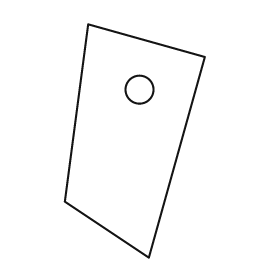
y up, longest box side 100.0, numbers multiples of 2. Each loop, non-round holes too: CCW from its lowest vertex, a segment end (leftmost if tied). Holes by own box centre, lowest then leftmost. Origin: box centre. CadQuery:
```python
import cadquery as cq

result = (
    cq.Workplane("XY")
    .moveTo(6.0, -50.0)
    .lineTo(30.0, 36.0)
    .lineTo(-20.0, 50.0)
    .lineTo(-30.0, -26.0)
    .close()
    .moveTo(2.0, 22.0)
    .circle(6.0)
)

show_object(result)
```